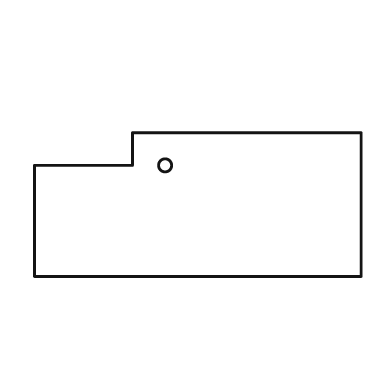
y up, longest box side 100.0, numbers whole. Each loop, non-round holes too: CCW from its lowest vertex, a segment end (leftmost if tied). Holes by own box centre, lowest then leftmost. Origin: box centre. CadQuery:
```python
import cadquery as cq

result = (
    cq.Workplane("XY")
    .moveTo(-50.0, -22.0)
    .lineTo(50.0, -22.0)
    .lineTo(50.0, 22.0)
    .lineTo(-20.0, 22.0)
    .lineTo(-20.0, 12.0)
    .lineTo(-50.0, 12.0)
    .close()
    .moveTo(-10.0, 12.0)
    .circle(2.0)
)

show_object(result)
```